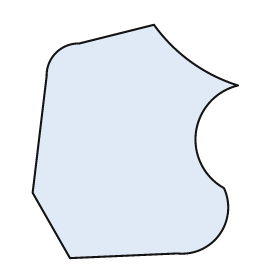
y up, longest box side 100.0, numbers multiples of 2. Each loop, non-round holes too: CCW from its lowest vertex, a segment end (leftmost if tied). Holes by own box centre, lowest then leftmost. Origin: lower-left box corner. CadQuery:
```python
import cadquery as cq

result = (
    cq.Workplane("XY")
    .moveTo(16.0, 0.0)
    .lineTo(62.0, 2.0)
    .threePointArc((80.0, 10.0), (82.0, 30.0))
    .threePointArc((70.0, 54.0), (88.0, 74.0))
    .threePointArc((68.0, 84.0), (52.0, 100.0))
    .lineTo(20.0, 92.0)
    .threePointArc((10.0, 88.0), (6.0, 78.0))
    .lineTo(0.0, 28.0)
    .close()
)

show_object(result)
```